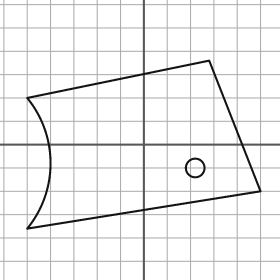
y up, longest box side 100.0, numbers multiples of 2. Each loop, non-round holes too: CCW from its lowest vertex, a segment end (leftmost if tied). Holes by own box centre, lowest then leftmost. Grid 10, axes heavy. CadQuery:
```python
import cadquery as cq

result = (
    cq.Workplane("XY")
    .moveTo(-50.0, -36.0)
    .lineTo(50.0, -20.0)
    .lineTo(28.0, 36.0)
    .lineTo(-50.0, 20.0)
    .threePointArc((-40.0, -8.0), (-50.0, -36.0))
    .close()
    .moveTo(22.0, -10.0)
    .circle(4.0)
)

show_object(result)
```